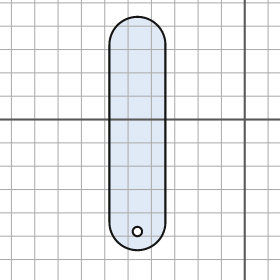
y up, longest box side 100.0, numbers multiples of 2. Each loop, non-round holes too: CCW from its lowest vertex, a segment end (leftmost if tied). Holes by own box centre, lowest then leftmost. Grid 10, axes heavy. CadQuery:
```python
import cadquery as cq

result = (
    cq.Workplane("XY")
    .moveTo(-58.0, -44.0)
    .threePointArc((-46.0, -56.0), (-34.0, -44.0))
    .lineTo(-34.0, 32.0)
    .threePointArc((-46.0, 44.0), (-58.0, 32.0))
    .close()
    .moveTo(-46.0, -48.0)
    .circle(2.0)
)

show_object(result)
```